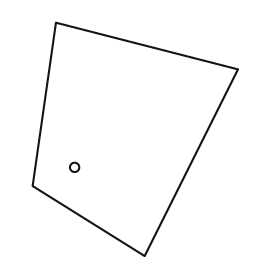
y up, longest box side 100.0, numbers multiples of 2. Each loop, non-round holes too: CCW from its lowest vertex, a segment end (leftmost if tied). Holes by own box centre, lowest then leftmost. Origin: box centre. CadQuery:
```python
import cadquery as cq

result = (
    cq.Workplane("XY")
    .moveTo(4.0, -50.0)
    .lineTo(44.0, 30.0)
    .lineTo(-34.0, 50.0)
    .lineTo(-44.0, -20.0)
    .close()
    .moveTo(-26.0, -12.0)
    .circle(2.0)
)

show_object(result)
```